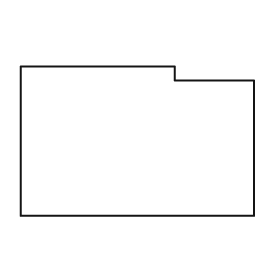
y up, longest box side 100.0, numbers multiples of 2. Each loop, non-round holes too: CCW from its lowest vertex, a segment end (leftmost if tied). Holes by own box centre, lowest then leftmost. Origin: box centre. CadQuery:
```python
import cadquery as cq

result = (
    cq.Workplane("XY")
    .moveTo(-50.0, -32.0)
    .lineTo(50.0, -32.0)
    .lineTo(50.0, 26.0)
    .lineTo(16.0, 26.0)
    .lineTo(16.0, 32.0)
    .lineTo(-50.0, 32.0)
    .close()
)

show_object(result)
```